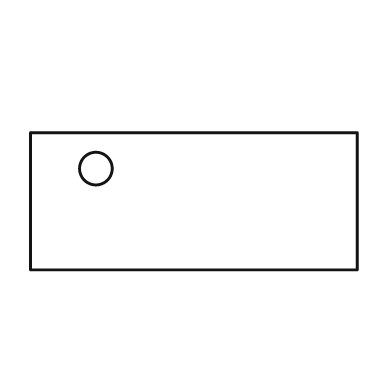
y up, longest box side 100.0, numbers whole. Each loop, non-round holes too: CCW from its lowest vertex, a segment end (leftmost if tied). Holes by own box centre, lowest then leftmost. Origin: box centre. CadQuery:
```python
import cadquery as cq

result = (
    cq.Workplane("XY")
    .moveTo(-50.0, -21.0)
    .lineTo(50.0, -21.0)
    .lineTo(50.0, 21.0)
    .lineTo(-50.0, 21.0)
    .close()
    .moveTo(-30.0, 10.0)
    .circle(5.0)
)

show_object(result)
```